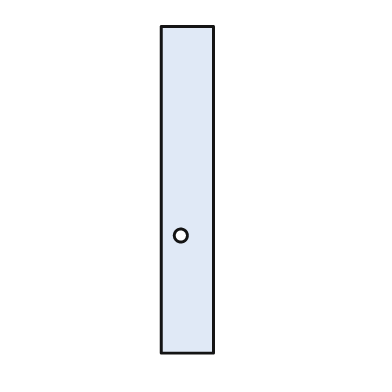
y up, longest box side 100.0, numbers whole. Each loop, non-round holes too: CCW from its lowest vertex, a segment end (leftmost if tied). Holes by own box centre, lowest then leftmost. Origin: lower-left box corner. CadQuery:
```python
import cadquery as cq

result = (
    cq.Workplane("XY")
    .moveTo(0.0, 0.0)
    .lineTo(16.0, 0.0)
    .lineTo(16.0, 100.0)
    .lineTo(0.0, 100.0)
    .close()
    .moveTo(6.0, 36.0)
    .circle(2.0)
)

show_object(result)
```